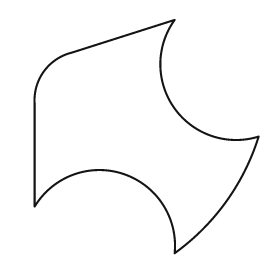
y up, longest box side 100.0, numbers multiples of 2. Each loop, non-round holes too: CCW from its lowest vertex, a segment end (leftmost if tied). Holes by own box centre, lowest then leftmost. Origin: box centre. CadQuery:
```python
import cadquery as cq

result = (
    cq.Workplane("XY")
    .moveTo(12.0, -50.0)
    .threePointArc((34.0, -28.0), (48.0, 0.0))
    .threePointArc((12.0, 12.0), (12.0, 50.0))
    .lineTo(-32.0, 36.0)
    .threePointArc((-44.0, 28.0), (-48.0, 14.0))
    .lineTo(-48.0, -30.0)
    .threePointArc((-10.0, -16.0), (12.0, -50.0))
    .close()
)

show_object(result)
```